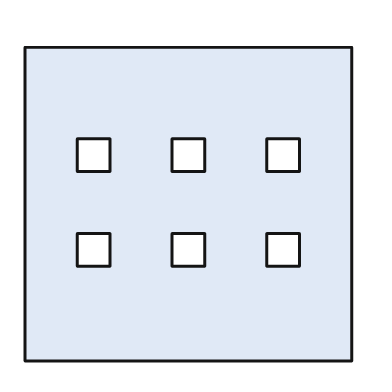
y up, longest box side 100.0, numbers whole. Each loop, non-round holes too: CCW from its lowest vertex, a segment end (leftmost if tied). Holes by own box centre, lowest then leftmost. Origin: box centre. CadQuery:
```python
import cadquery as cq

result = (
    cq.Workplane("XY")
    .moveTo(-50.0, -48.0)
    .lineTo(50.0, -48.0)
    .lineTo(50.0, 48.0)
    .lineTo(-50.0, 48.0)
    .close()
    .moveTo(-34.0, -19.0)
    .lineTo(-24.0, -19.0)
    .lineTo(-24.0, -9.0)
    .lineTo(-34.0, -9.0)
    .close()
    .moveTo(-5.0, -19.0)
    .lineTo(5.0, -19.0)
    .lineTo(5.0, -9.0)
    .lineTo(-5.0, -9.0)
    .close()
    .moveTo(24.0, -19.0)
    .lineTo(34.0, -19.0)
    .lineTo(34.0, -9.0)
    .lineTo(24.0, -9.0)
    .close()
    .moveTo(-34.0, 10.0)
    .lineTo(-24.0, 10.0)
    .lineTo(-24.0, 20.0)
    .lineTo(-34.0, 20.0)
    .close()
    .moveTo(-5.0, 10.0)
    .lineTo(5.0, 10.0)
    .lineTo(5.0, 20.0)
    .lineTo(-5.0, 20.0)
    .close()
    .moveTo(24.0, 10.0)
    .lineTo(34.0, 10.0)
    .lineTo(34.0, 20.0)
    .lineTo(24.0, 20.0)
    .close()
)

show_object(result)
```